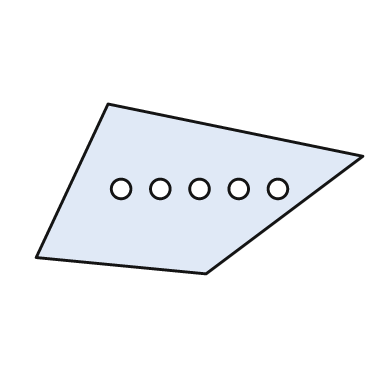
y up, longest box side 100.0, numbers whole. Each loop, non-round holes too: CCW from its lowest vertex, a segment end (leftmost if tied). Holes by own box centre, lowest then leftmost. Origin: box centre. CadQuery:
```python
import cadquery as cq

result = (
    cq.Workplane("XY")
    .moveTo(2.0, -26.0)
    .lineTo(50.0, 10.0)
    .lineTo(-28.0, 26.0)
    .lineTo(-50.0, -21.0)
    .close()
    .moveTo(-24.0, 0.0)
    .circle(3.0)
    .moveTo(-12.0, 0.0)
    .circle(3.0)
    .moveTo(0.0, 0.0)
    .circle(3.0)
    .moveTo(12.0, 0.0)
    .circle(3.0)
    .moveTo(24.0, 0.0)
    .circle(3.0)
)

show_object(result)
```